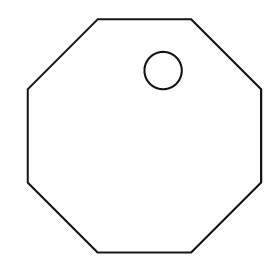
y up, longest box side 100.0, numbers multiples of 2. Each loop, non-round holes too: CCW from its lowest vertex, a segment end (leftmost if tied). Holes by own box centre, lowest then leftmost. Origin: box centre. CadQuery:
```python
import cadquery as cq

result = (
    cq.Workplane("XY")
    .moveTo(-20.0, -50.0)
    .lineTo(20.0, -50.0)
    .lineTo(50.0, -20.0)
    .lineTo(50.0, 20.0)
    .lineTo(20.0, 50.0)
    .lineTo(-20.0, 50.0)
    .lineTo(-50.0, 20.0)
    .lineTo(-50.0, -20.0)
    .close()
    .moveTo(8.0, 28.0)
    .circle(8.0)
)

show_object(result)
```